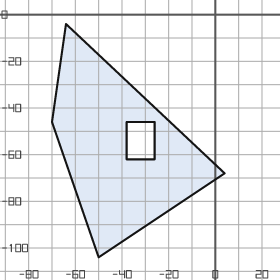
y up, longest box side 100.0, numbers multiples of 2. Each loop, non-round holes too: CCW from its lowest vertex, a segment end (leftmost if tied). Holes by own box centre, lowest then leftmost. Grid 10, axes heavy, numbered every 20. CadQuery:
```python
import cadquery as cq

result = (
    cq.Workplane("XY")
    .moveTo(-50.0, -104.0)
    .lineTo(4.0, -68.0)
    .lineTo(-64.0, -4.0)
    .lineTo(-70.0, -46.0)
    .close()
    .moveTo(-38.0, -62.0)
    .lineTo(-26.0, -62.0)
    .lineTo(-26.0, -46.0)
    .lineTo(-38.0, -46.0)
    .close()
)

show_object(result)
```